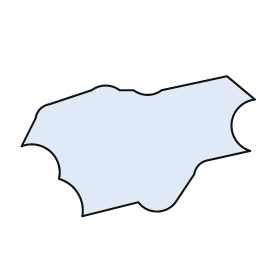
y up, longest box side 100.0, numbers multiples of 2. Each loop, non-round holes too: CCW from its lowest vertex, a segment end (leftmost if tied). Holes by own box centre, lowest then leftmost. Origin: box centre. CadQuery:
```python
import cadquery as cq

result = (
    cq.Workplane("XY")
    .moveTo(-24.0, -30.0)
    .lineTo(0.0, -24.0)
    .threePointArc((8.0, -28.0), (16.0, -24.0))
    .lineTo(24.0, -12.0)
    .threePointArc((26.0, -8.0), (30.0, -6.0))
    .lineTo(48.0, -2.0)
    .threePointArc((40.0, 10.0), (50.0, 20.0))
    .lineTo(38.0, 30.0)
    .lineTo(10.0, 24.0)
    .threePointArc((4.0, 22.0), (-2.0, 24.0))
    .lineTo(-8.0, 24.0)
    .threePointArc((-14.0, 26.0), (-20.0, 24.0))
    .lineTo(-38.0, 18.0)
    .threePointArc((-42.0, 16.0), (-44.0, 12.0))
    .lineTo(-50.0, 0.0)
    .threePointArc((-38.0, -2.0), (-34.0, -14.0))
    .threePointArc((-26.0, -20.0), (-24.0, -30.0))
    .close()
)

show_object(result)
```